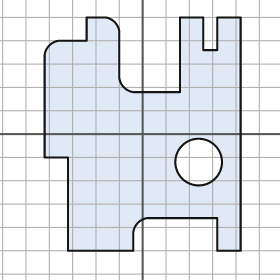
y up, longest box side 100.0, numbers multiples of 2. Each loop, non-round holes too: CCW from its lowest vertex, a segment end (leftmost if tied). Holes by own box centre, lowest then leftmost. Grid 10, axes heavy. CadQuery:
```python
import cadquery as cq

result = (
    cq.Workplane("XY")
    .moveTo(-32.0, -50.0)
    .lineTo(-4.0, -50.0)
    .lineTo(-4.0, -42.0)
    .threePointArc((-2.0, -38.0), (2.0, -36.0))
    .lineTo(32.0, -36.0)
    .lineTo(32.0, -50.0)
    .lineTo(42.0, -50.0)
    .lineTo(42.0, 50.0)
    .lineTo(32.0, 50.0)
    .lineTo(32.0, 36.0)
    .lineTo(26.0, 36.0)
    .lineTo(26.0, 50.0)
    .lineTo(16.0, 50.0)
    .lineTo(16.0, 18.0)
    .lineTo(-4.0, 18.0)
    .threePointArc((-8.0, 20.0), (-10.0, 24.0))
    .lineTo(-10.0, 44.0)
    .threePointArc((-12.0, 48.0), (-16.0, 50.0))
    .lineTo(-24.0, 50.0)
    .lineTo(-24.0, 40.0)
    .lineTo(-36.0, 40.0)
    .threePointArc((-40.0, 38.0), (-42.0, 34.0))
    .lineTo(-42.0, -10.0)
    .lineTo(-32.0, -10.0)
    .close()
    .moveTo(24.0, -12.0)
    .circle(10.0)
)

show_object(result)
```